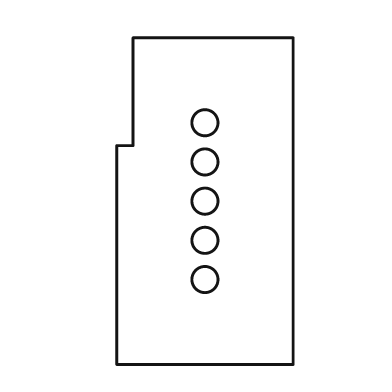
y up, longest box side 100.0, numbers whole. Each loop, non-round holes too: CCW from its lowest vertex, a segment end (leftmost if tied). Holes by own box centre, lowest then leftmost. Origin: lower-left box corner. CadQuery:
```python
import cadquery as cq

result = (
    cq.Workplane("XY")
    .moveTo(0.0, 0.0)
    .lineTo(54.0, 0.0)
    .lineTo(54.0, 100.0)
    .lineTo(5.0, 100.0)
    .lineTo(5.0, 67.0)
    .lineTo(0.0, 67.0)
    .close()
    .moveTo(27.0, 26.0)
    .circle(4.0)
    .moveTo(27.0, 38.0)
    .circle(4.0)
    .moveTo(27.0, 50.0)
    .circle(4.0)
    .moveTo(27.0, 62.0)
    .circle(4.0)
    .moveTo(27.0, 74.0)
    .circle(4.0)
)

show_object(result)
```